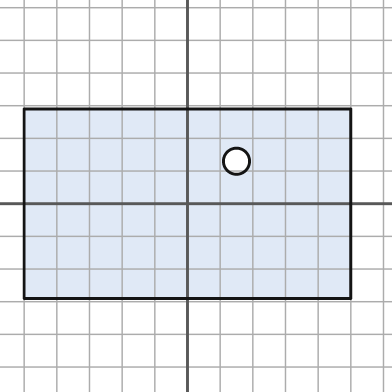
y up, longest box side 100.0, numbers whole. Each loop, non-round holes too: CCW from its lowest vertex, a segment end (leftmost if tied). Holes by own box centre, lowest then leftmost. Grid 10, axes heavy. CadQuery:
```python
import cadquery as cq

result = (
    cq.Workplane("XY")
    .moveTo(-50.0, -29.0)
    .lineTo(50.0, -29.0)
    .lineTo(50.0, 29.0)
    .lineTo(-50.0, 29.0)
    .close()
    .moveTo(15.0, 13.0)
    .circle(4.0)
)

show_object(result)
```